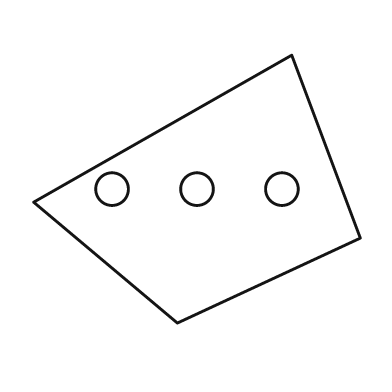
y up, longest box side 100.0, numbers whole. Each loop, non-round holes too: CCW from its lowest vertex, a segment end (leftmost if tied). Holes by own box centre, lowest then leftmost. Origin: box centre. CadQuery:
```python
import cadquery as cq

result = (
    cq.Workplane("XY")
    .moveTo(-6.0, -41.0)
    .lineTo(50.0, -15.0)
    .lineTo(29.0, 41.0)
    .lineTo(-50.0, -4.0)
    .close()
    .moveTo(-26.0, 0.0)
    .circle(5.0)
    .moveTo(0.0, 0.0)
    .circle(5.0)
    .moveTo(26.0, 0.0)
    .circle(5.0)
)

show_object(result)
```